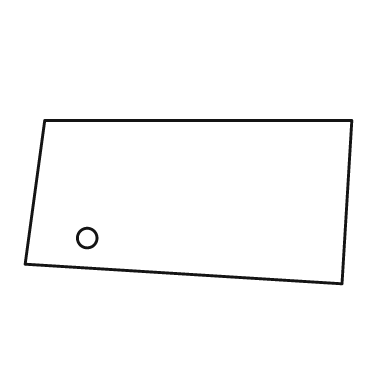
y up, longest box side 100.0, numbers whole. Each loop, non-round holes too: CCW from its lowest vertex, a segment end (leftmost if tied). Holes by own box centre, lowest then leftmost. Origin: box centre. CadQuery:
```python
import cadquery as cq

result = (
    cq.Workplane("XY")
    .moveTo(47.0, -25.0)
    .lineTo(50.0, 25.0)
    .lineTo(-44.0, 25.0)
    .lineTo(-50.0, -19.0)
    .close()
    .moveTo(-31.0, -11.0)
    .circle(3.0)
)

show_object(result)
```